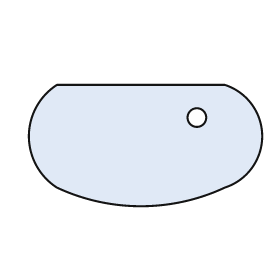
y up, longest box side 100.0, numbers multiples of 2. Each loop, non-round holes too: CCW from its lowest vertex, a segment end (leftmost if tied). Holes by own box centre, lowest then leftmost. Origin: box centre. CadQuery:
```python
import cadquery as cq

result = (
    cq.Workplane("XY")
    .moveTo(-38.0, -18.0)
    .threePointArc((-2.0, -26.0), (34.0, -18.0))
    .threePointArc((50.0, 4.0), (34.0, 26.0))
    .lineTo(-38.0, 26.0)
    .threePointArc((-50.0, 4.0), (-38.0, -18.0))
    .close()
    .moveTo(22.0, 12.0)
    .circle(4.0)
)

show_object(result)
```